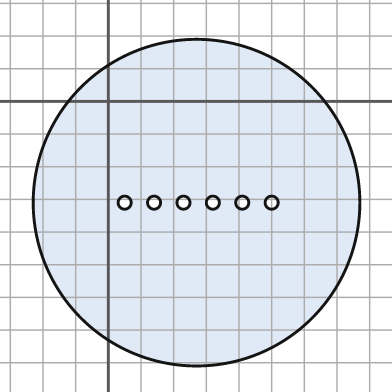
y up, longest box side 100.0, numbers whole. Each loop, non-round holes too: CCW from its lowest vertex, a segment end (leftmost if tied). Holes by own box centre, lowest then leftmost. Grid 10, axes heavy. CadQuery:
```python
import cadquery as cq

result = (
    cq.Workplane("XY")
    .moveTo(27.0, -31.0)
    .circle(50.0)
    .moveTo(5.0, -31.0)
    .circle(2.0)
    .moveTo(14.0, -31.0)
    .circle(2.0)
    .moveTo(23.0, -31.0)
    .circle(2.0)
    .moveTo(32.0, -31.0)
    .circle(2.0)
    .moveTo(41.0, -31.0)
    .circle(2.0)
    .moveTo(50.0, -31.0)
    .circle(2.0)
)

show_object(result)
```